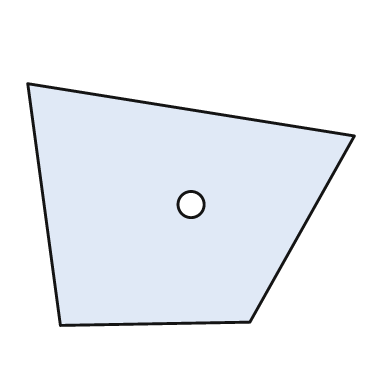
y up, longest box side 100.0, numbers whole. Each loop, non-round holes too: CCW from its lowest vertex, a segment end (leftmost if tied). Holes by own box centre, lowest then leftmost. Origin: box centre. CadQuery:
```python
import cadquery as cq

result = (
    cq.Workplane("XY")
    .moveTo(-40.0, -37.0)
    .lineTo(18.0, -36.0)
    .lineTo(50.0, 21.0)
    .lineTo(-50.0, 37.0)
    .close()
    .moveTo(0.0, 0.0)
    .circle(4.0)
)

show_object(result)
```